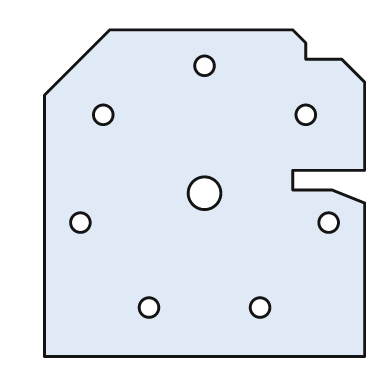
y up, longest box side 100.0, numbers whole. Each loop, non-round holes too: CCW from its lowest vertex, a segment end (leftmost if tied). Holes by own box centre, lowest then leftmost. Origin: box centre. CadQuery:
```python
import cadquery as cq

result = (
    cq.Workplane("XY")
    .moveTo(-49.0, -50.0)
    .lineTo(49.0, -50.0)
    .lineTo(49.0, -3.0)
    .lineTo(39.0, 1.0)
    .lineTo(27.0, 1.0)
    .lineTo(27.0, 7.0)
    .lineTo(49.0, 7.0)
    .lineTo(49.0, 34.0)
    .lineTo(42.0, 41.0)
    .lineTo(31.0, 41.0)
    .lineTo(31.0, 46.0)
    .lineTo(27.0, 50.0)
    .lineTo(-29.0, 50.0)
    .lineTo(-49.0, 30.0)
    .close()
    .moveTo(-17.0, -35.0)
    .circle(3.0)
    .moveTo(17.0, -35.0)
    .circle(3.0)
    .moveTo(-38.0, -9.0)
    .circle(3.0)
    .moveTo(38.0, -9.0)
    .circle(3.0)
    .moveTo(0.0, 0.0)
    .circle(5.0)
    .moveTo(-31.0, 24.0)
    .circle(3.0)
    .moveTo(31.0, 24.0)
    .circle(3.0)
    .moveTo(0.0, 39.0)
    .circle(3.0)
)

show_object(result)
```